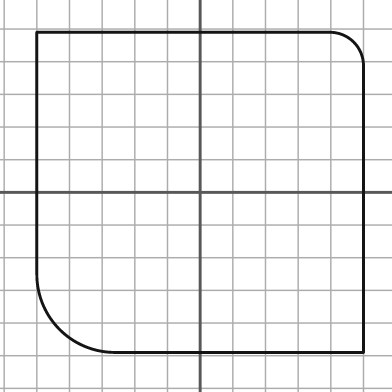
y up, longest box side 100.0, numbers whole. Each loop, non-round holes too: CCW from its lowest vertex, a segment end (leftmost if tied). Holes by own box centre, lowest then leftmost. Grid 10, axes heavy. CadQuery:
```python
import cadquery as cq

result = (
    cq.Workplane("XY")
    .moveTo(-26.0, -49.0)
    .lineTo(50.0, -49.0)
    .lineTo(50.0, 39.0)
    .threePointArc((47.0, 46.0), (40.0, 49.0))
    .lineTo(-50.0, 49.0)
    .lineTo(-50.0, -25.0)
    .threePointArc((-43.0, -42.0), (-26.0, -49.0))
    .close()
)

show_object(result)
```